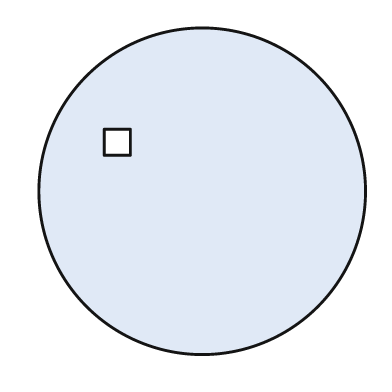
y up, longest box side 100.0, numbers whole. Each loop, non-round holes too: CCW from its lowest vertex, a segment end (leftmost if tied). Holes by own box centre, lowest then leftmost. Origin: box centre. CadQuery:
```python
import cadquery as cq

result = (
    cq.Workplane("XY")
    .moveTo(0.0, 0.0)
    .circle(50.0)
    .moveTo(-30.0, 11.0)
    .lineTo(-22.0, 11.0)
    .lineTo(-22.0, 19.0)
    .lineTo(-30.0, 19.0)
    .close()
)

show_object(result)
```